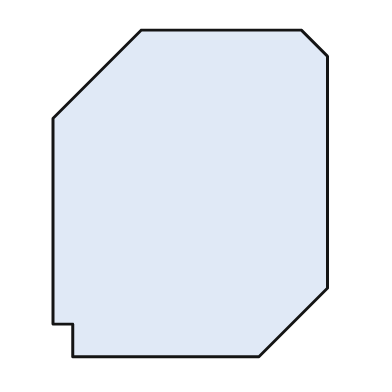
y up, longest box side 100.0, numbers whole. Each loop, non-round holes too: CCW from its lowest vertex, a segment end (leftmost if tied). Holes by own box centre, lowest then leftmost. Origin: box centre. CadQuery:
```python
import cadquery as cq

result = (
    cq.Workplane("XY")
    .moveTo(-36.0, -50.0)
    .lineTo(21.0, -50.0)
    .lineTo(42.0, -29.0)
    .lineTo(42.0, 42.0)
    .lineTo(34.0, 50.0)
    .lineTo(-15.0, 50.0)
    .lineTo(-42.0, 23.0)
    .lineTo(-42.0, -40.0)
    .lineTo(-36.0, -40.0)
    .close()
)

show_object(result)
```